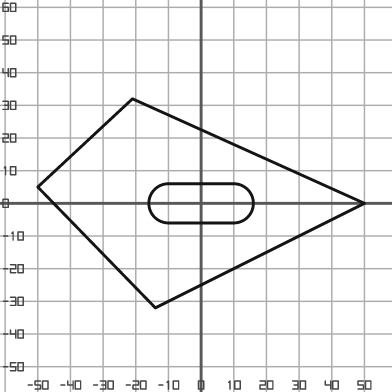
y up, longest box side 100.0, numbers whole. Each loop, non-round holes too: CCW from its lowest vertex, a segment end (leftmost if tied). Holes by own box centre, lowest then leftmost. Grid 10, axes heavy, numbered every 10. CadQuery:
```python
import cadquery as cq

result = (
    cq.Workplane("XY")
    .moveTo(-14.0, -32.0)
    .lineTo(50.0, 0.0)
    .lineTo(-21.0, 32.0)
    .lineTo(-50.0, 5.0)
    .close()
    .moveTo(-10.0, -6.0)
    .lineTo(10.0, -6.0)
    .threePointArc((16.0, 0.0), (10.0, 6.0))
    .lineTo(-10.0, 6.0)
    .threePointArc((-16.0, 0.0), (-10.0, -6.0))
    .close()
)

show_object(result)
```